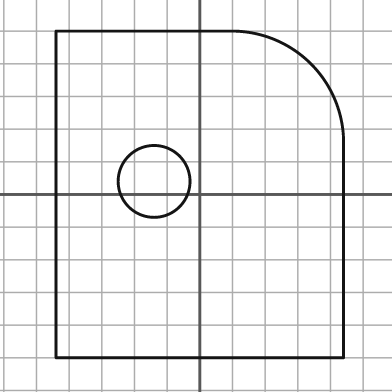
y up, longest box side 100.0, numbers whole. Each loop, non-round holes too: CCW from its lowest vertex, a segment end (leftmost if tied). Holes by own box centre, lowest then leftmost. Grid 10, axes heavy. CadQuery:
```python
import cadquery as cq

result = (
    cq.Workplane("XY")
    .moveTo(-44.0, -50.0)
    .lineTo(44.0, -50.0)
    .lineTo(44.0, 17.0)
    .threePointArc((34.0, 40.0), (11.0, 50.0))
    .lineTo(-44.0, 50.0)
    .close()
    .moveTo(-14.0, 4.0)
    .circle(11.0)
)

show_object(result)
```